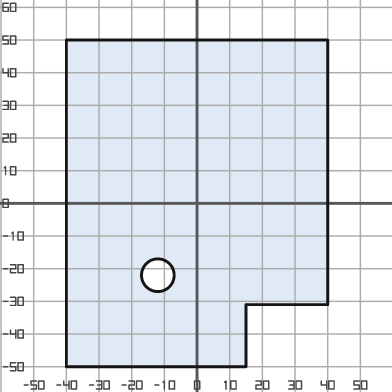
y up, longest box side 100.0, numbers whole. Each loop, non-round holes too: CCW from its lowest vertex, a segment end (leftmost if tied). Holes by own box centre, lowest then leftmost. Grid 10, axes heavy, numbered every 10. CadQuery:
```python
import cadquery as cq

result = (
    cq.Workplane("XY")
    .moveTo(-40.0, -50.0)
    .lineTo(15.0, -50.0)
    .lineTo(15.0, -31.0)
    .lineTo(40.0, -31.0)
    .lineTo(40.0, 50.0)
    .lineTo(-40.0, 50.0)
    .close()
    .moveTo(-12.0, -22.0)
    .circle(5.0)
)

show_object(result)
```